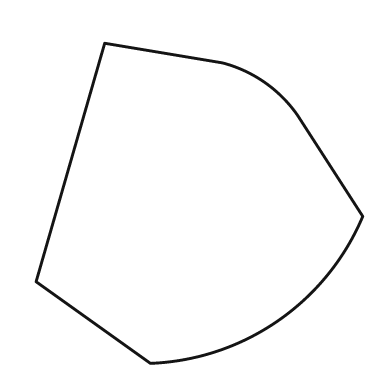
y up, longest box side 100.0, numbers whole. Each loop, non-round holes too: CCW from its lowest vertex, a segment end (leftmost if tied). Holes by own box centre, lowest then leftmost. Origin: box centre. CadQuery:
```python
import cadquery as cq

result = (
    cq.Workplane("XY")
    .moveTo(-15.0, -49.0)
    .threePointArc((24.0, -36.0), (50.0, -4.0))
    .lineTo(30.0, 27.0)
    .threePointArc((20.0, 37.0), (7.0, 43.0))
    .lineTo(-29.0, 49.0)
    .lineTo(-50.0, -24.0)
    .close()
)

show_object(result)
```